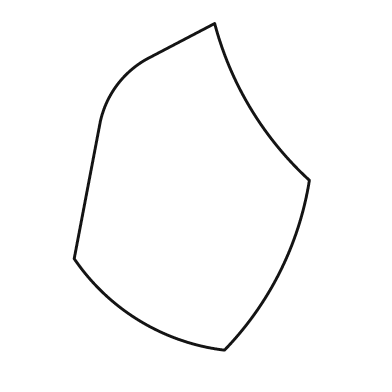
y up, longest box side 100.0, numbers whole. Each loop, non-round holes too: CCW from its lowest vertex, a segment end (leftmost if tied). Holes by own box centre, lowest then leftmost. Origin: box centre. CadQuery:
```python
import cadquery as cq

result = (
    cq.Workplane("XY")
    .moveTo(10.0, -50.0)
    .threePointArc((27.0, -26.0), (36.0, 2.0))
    .threePointArc((18.0, 24.0), (7.0, 50.0))
    .lineTo(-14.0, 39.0)
    .threePointArc((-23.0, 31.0), (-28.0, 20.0))
    .lineTo(-36.0, -22.0)
    .threePointArc((-16.0, -41.0), (10.0, -50.0))
    .close()
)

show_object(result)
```